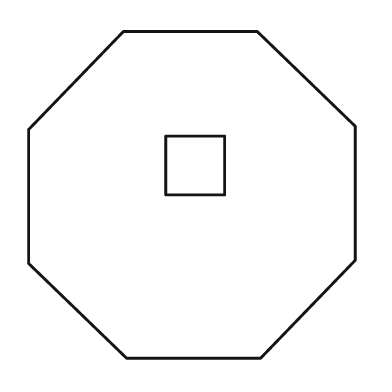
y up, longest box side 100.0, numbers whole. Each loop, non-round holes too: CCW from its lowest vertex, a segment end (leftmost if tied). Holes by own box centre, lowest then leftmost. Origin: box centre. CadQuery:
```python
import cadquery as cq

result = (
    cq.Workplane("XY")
    .moveTo(-20.0, -50.0)
    .lineTo(21.0, -50.0)
    .lineTo(50.0, -20.0)
    .lineTo(50.0, 21.0)
    .lineTo(20.0, 50.0)
    .lineTo(-21.0, 50.0)
    .lineTo(-50.0, 20.0)
    .lineTo(-50.0, -21.0)
    .close()
    .moveTo(-8.0, 0.0)
    .lineTo(10.0, 0.0)
    .lineTo(10.0, 18.0)
    .lineTo(-8.0, 18.0)
    .close()
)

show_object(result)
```